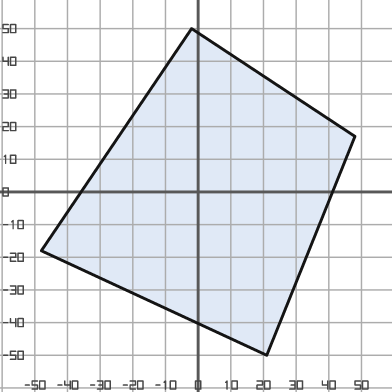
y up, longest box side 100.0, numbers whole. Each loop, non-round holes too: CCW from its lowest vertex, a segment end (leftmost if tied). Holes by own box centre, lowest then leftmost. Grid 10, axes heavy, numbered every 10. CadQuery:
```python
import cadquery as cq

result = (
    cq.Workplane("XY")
    .moveTo(21.0, -50.0)
    .lineTo(48.0, 17.0)
    .lineTo(-2.0, 50.0)
    .lineTo(-48.0, -18.0)
    .close()
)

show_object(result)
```